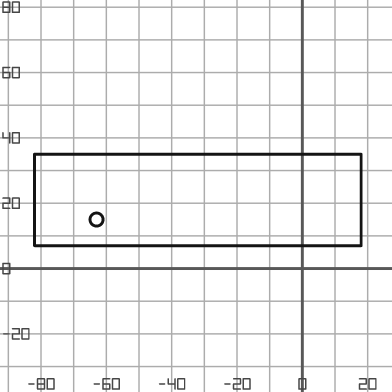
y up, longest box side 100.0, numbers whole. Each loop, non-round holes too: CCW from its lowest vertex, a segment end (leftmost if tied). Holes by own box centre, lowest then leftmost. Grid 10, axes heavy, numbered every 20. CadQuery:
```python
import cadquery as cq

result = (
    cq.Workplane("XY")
    .moveTo(-82.0, 7.0)
    .lineTo(18.0, 7.0)
    .lineTo(18.0, 35.0)
    .lineTo(-82.0, 35.0)
    .close()
    .moveTo(-63.0, 15.0)
    .circle(2.0)
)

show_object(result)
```